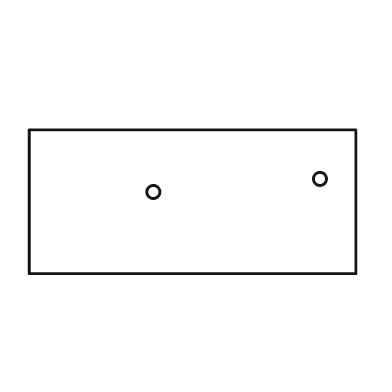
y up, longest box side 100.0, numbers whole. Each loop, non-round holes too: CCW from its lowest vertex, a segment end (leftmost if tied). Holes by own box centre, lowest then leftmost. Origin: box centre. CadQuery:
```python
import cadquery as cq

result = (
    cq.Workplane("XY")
    .moveTo(-50.0, -22.0)
    .lineTo(50.0, -22.0)
    .lineTo(50.0, 22.0)
    .lineTo(-50.0, 22.0)
    .close()
    .moveTo(-12.0, 3.0)
    .circle(2.0)
    .moveTo(39.0, 7.0)
    .circle(2.0)
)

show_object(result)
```